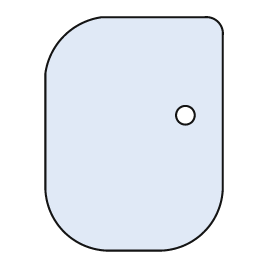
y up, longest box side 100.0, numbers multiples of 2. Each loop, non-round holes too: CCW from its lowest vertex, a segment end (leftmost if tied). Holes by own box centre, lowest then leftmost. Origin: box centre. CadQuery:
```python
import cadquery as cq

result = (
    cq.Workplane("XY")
    .moveTo(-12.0, -50.0)
    .lineTo(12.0, -50.0)
    .threePointArc((30.0, -42.0), (38.0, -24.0))
    .lineTo(38.0, 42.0)
    .threePointArc((36.0, 48.0), (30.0, 50.0))
    .lineTo(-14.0, 50.0)
    .threePointArc((-30.0, 42.0), (-38.0, 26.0))
    .lineTo(-38.0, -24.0)
    .threePointArc((-30.0, -42.0), (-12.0, -50.0))
    .close()
    .moveTo(22.0, 8.0)
    .circle(4.0)
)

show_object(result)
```